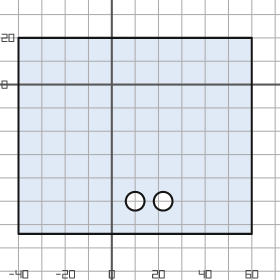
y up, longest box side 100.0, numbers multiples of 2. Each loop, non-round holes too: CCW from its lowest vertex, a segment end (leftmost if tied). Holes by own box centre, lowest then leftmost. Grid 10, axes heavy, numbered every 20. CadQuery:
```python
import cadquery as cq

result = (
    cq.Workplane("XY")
    .moveTo(-40.0, -64.0)
    .lineTo(60.0, -64.0)
    .lineTo(60.0, 20.0)
    .lineTo(-40.0, 20.0)
    .close()
    .moveTo(10.0, -50.0)
    .circle(4.0)
    .moveTo(22.0, -50.0)
    .circle(4.0)
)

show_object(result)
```